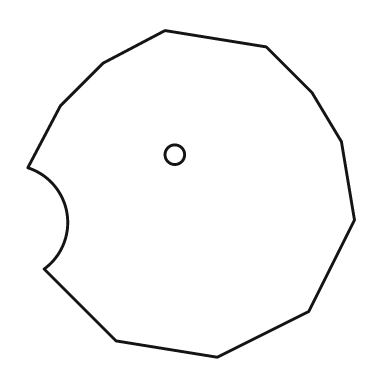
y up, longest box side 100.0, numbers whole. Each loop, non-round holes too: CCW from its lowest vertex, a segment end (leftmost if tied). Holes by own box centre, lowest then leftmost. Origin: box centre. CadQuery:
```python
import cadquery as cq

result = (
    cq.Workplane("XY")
    .moveTo(8.0, -50.0)
    .lineTo(36.0, -36.0)
    .lineTo(50.0, -8.0)
    .lineTo(46.0, 16.0)
    .lineTo(37.0, 31.0)
    .lineTo(23.0, 45.0)
    .lineTo(-8.0, 50.0)
    .lineTo(-27.0, 40.0)
    .lineTo(-40.0, 27.0)
    .lineTo(-50.0, 8.0)
    .threePointArc((-38.0, -6.0), (-45.0, -23.0))
    .lineTo(-23.0, -45.0)
    .close()
    .moveTo(-5.0, 12.0)
    .circle(3.0)
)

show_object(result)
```